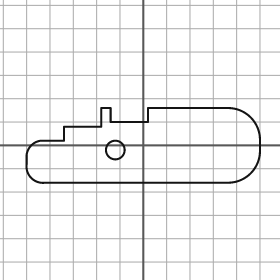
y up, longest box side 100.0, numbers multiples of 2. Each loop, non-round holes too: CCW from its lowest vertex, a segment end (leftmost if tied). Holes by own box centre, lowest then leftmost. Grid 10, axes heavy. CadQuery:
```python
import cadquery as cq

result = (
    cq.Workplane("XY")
    .moveTo(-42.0, -16.0)
    .lineTo(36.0, -16.0)
    .threePointArc((46.0, -12.0), (50.0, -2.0))
    .lineTo(50.0, 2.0)
    .threePointArc((46.0, 12.0), (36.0, 16.0))
    .lineTo(2.0, 16.0)
    .lineTo(2.0, 10.0)
    .lineTo(-14.0, 10.0)
    .lineTo(-14.0, 16.0)
    .lineTo(-18.0, 16.0)
    .lineTo(-18.0, 8.0)
    .lineTo(-34.0, 8.0)
    .lineTo(-34.0, 2.0)
    .lineTo(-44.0, 2.0)
    .threePointArc((-48.0, 0.0), (-50.0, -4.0))
    .lineTo(-50.0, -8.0)
    .threePointArc((-48.0, -14.0), (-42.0, -16.0))
    .close()
    .moveTo(-12.0, -2.0)
    .circle(4.0)
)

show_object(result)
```